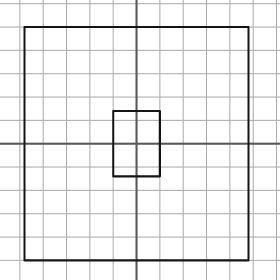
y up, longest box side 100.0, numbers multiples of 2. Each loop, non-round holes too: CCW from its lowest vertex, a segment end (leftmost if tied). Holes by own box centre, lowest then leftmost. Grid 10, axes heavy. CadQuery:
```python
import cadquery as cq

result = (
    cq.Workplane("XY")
    .moveTo(-48.0, -50.0)
    .lineTo(48.0, -50.0)
    .lineTo(48.0, 50.0)
    .lineTo(-48.0, 50.0)
    .close()
    .moveTo(-10.0, -14.0)
    .lineTo(10.0, -14.0)
    .lineTo(10.0, 14.0)
    .lineTo(-10.0, 14.0)
    .close()
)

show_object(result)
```